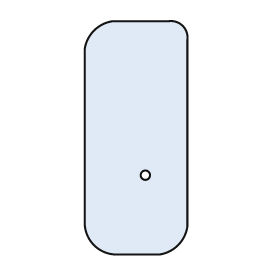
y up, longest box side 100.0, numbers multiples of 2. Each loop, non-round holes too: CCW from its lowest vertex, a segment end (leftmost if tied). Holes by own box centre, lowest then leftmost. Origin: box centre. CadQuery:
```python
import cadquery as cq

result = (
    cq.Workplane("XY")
    .moveTo(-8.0, -50.0)
    .lineTo(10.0, -50.0)
    .threePointArc((18.0, -46.0), (22.0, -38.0))
    .lineTo(22.0, 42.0)
    .threePointArc((20.0, 48.0), (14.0, 50.0))
    .lineTo(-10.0, 50.0)
    .threePointArc((-18.0, 46.0), (-22.0, 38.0))
    .lineTo(-22.0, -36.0)
    .threePointArc((-18.0, -46.0), (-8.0, -50.0))
    .close()
    .moveTo(4.0, -16.0)
    .circle(2.0)
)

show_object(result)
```